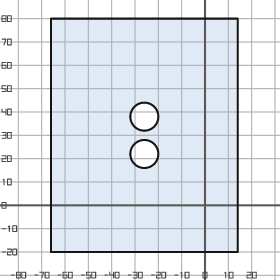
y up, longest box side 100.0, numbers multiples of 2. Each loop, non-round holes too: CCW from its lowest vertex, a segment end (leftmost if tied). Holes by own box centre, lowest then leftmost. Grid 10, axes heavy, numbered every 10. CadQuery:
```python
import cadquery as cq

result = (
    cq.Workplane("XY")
    .moveTo(-66.0, -20.0)
    .lineTo(14.0, -20.0)
    .lineTo(14.0, 80.0)
    .lineTo(-66.0, 80.0)
    .close()
    .moveTo(-26.0, 22.0)
    .circle(6.0)
    .moveTo(-26.0, 38.0)
    .circle(6.0)
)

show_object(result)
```